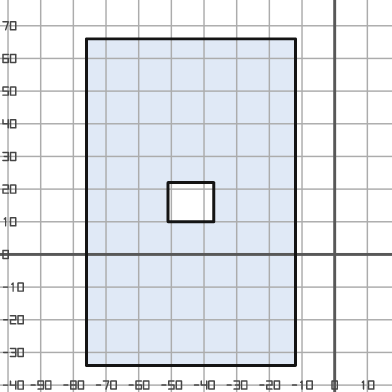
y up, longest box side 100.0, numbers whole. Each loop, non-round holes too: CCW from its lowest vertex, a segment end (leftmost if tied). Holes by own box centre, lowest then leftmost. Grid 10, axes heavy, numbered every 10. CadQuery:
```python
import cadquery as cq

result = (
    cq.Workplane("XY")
    .moveTo(-76.0, -34.0)
    .lineTo(-12.0, -34.0)
    .lineTo(-12.0, 66.0)
    .lineTo(-76.0, 66.0)
    .close()
    .moveTo(-51.0, 10.0)
    .lineTo(-37.0, 10.0)
    .lineTo(-37.0, 22.0)
    .lineTo(-51.0, 22.0)
    .close()
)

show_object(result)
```